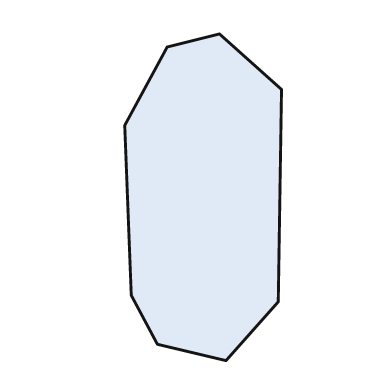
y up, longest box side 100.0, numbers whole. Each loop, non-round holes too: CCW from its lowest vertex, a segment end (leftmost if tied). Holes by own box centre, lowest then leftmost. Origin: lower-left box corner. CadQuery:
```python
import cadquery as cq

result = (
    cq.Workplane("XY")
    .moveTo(31.0, 0.0)
    .lineTo(47.0, 18.0)
    .lineTo(48.0, 83.0)
    .lineTo(29.0, 100.0)
    .lineTo(13.0, 96.0)
    .lineTo(0.0, 72.0)
    .lineTo(2.0, 20.0)
    .lineTo(10.0, 5.0)
    .close()
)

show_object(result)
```